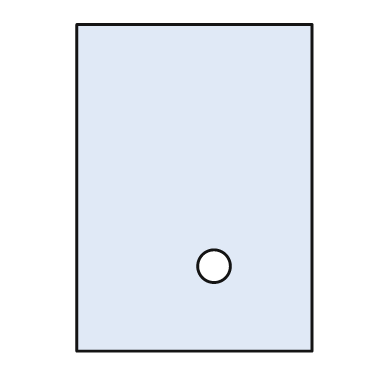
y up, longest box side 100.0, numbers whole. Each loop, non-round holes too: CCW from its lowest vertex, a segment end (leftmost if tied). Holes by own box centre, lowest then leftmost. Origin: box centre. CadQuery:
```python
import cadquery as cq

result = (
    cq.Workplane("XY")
    .moveTo(-36.0, -50.0)
    .lineTo(36.0, -50.0)
    .lineTo(36.0, 50.0)
    .lineTo(-36.0, 50.0)
    .close()
    .moveTo(6.0, -24.0)
    .circle(5.0)
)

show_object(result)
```